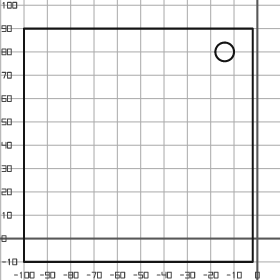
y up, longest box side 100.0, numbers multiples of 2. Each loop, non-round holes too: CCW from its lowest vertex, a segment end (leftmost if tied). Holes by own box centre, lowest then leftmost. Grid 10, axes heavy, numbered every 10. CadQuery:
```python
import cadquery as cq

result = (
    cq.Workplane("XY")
    .moveTo(-100.0, -10.0)
    .lineTo(-2.0, -10.0)
    .lineTo(-2.0, 90.0)
    .lineTo(-100.0, 90.0)
    .close()
    .moveTo(-14.0, 80.0)
    .circle(4.0)
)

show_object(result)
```